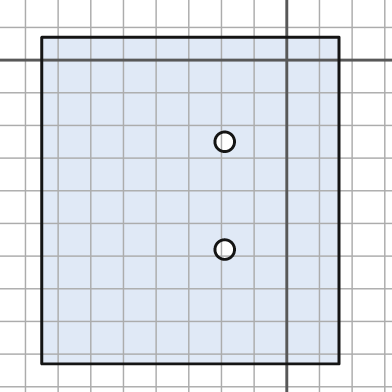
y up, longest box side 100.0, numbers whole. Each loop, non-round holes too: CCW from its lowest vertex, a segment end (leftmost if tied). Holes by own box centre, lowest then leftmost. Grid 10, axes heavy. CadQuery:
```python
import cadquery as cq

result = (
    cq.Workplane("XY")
    .moveTo(-75.0, -93.0)
    .lineTo(16.0, -93.0)
    .lineTo(16.0, 7.0)
    .lineTo(-75.0, 7.0)
    .close()
    .moveTo(-19.0, -58.0)
    .circle(3.0)
    .moveTo(-19.0, -25.0)
    .circle(3.0)
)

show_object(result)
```